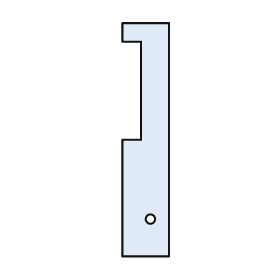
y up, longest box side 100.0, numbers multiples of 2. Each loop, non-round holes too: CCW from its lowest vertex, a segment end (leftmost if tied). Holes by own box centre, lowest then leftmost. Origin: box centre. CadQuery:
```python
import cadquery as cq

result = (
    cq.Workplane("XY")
    .moveTo(-10.0, -50.0)
    .lineTo(10.0, -50.0)
    .lineTo(10.0, 50.0)
    .lineTo(-10.0, 50.0)
    .lineTo(-10.0, 42.0)
    .lineTo(-2.0, 42.0)
    .lineTo(-2.0, 0.0)
    .lineTo(-10.0, 0.0)
    .close()
    .moveTo(2.0, -34.0)
    .circle(2.0)
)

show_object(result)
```